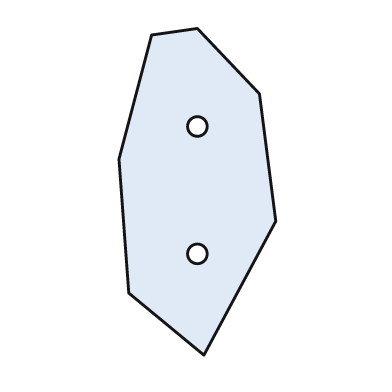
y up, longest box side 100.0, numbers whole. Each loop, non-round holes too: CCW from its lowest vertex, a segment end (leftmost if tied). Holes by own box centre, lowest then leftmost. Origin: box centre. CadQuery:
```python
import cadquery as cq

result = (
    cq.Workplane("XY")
    .moveTo(2.0, -50.0)
    .lineTo(24.0, -9.0)
    .lineTo(19.0, 30.0)
    .lineTo(0.0, 50.0)
    .lineTo(-14.0, 48.0)
    .lineTo(-24.0, 10.0)
    .lineTo(-21.0, -31.0)
    .close()
    .moveTo(0.0, -19.0)
    .circle(3.0)
    .moveTo(0.0, 20.0)
    .circle(3.0)
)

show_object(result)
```